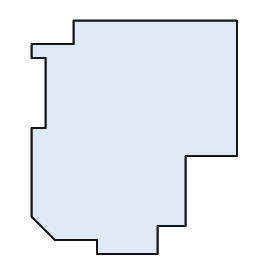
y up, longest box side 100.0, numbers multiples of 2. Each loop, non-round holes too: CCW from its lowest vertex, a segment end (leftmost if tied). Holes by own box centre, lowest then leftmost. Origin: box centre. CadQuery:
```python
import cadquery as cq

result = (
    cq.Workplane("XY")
    .moveTo(-16.0, -50.0)
    .lineTo(10.0, -50.0)
    .lineTo(10.0, -38.0)
    .lineTo(22.0, -38.0)
    .lineTo(22.0, -8.0)
    .lineTo(44.0, -8.0)
    .lineTo(44.0, 50.0)
    .lineTo(-26.0, 50.0)
    .lineTo(-26.0, 40.0)
    .lineTo(-44.0, 40.0)
    .lineTo(-44.0, 34.0)
    .lineTo(-38.0, 34.0)
    .lineTo(-38.0, 4.0)
    .lineTo(-44.0, 4.0)
    .lineTo(-44.0, -34.0)
    .lineTo(-34.0, -44.0)
    .lineTo(-16.0, -44.0)
    .close()
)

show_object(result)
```